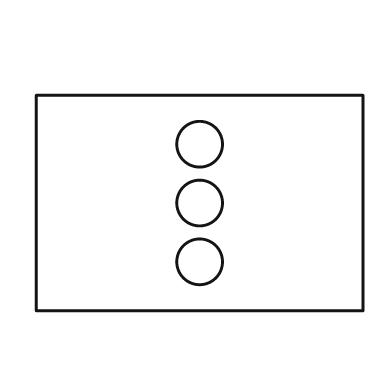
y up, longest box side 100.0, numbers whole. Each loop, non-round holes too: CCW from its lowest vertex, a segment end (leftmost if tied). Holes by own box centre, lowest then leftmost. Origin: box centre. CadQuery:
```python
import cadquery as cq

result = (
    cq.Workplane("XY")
    .moveTo(-50.0, -33.0)
    .lineTo(50.0, -33.0)
    .lineTo(50.0, 33.0)
    .lineTo(-50.0, 33.0)
    .close()
    .moveTo(0.0, -18.0)
    .circle(7.0)
    .moveTo(0.0, 0.0)
    .circle(7.0)
    .moveTo(0.0, 18.0)
    .circle(7.0)
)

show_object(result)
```